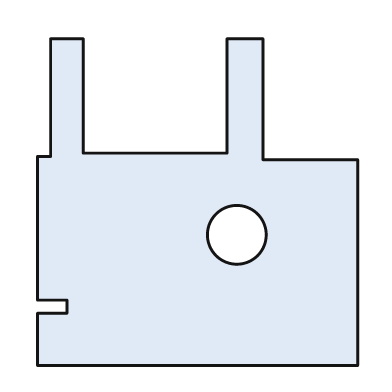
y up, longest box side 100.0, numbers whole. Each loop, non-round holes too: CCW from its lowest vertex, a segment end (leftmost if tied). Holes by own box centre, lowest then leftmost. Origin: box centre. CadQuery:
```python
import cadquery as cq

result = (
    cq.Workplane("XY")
    .moveTo(-49.0, -50.0)
    .lineTo(49.0, -50.0)
    .lineTo(49.0, 13.0)
    .lineTo(20.0, 13.0)
    .lineTo(20.0, 50.0)
    .lineTo(9.0, 50.0)
    .lineTo(9.0, 15.0)
    .lineTo(-35.0, 15.0)
    .lineTo(-35.0, 50.0)
    .lineTo(-45.0, 50.0)
    .lineTo(-45.0, 14.0)
    .lineTo(-49.0, 14.0)
    .lineTo(-49.0, -30.0)
    .lineTo(-40.0, -30.0)
    .lineTo(-40.0, -34.0)
    .lineTo(-49.0, -34.0)
    .close()
    .moveTo(12.0, -10.0)
    .circle(9.0)
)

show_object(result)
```